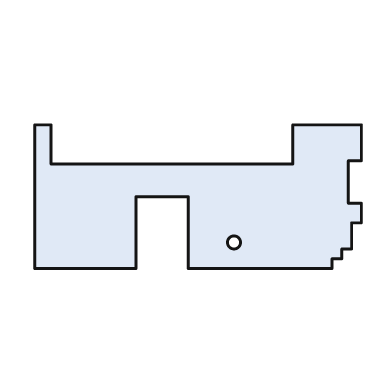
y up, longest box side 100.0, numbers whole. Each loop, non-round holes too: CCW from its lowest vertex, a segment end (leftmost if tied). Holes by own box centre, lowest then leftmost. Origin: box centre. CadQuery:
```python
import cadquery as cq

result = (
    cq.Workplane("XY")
    .moveTo(-50.0, -22.0)
    .lineTo(-19.0, -22.0)
    .lineTo(-19.0, 0.0)
    .lineTo(-3.0, 0.0)
    .lineTo(-3.0, -22.0)
    .lineTo(41.0, -22.0)
    .lineTo(41.0, -19.0)
    .lineTo(44.0, -19.0)
    .lineTo(44.0, -16.0)
    .lineTo(47.0, -16.0)
    .lineTo(47.0, -8.0)
    .lineTo(50.0, -8.0)
    .lineTo(50.0, -2.0)
    .lineTo(46.0, -2.0)
    .lineTo(46.0, 11.0)
    .lineTo(50.0, 11.0)
    .lineTo(50.0, 22.0)
    .lineTo(29.0, 22.0)
    .lineTo(29.0, 10.0)
    .lineTo(-45.0, 10.0)
    .lineTo(-45.0, 22.0)
    .lineTo(-50.0, 22.0)
    .close()
    .moveTo(11.0, -14.0)
    .circle(2.0)
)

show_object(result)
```